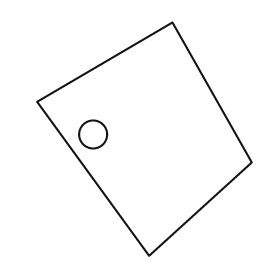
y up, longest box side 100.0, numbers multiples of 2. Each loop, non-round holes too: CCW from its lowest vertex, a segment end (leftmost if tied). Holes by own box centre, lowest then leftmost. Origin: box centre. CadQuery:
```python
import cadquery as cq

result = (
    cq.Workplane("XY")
    .moveTo(2.0, -50.0)
    .lineTo(46.0, -10.0)
    .lineTo(12.0, 50.0)
    .lineTo(-46.0, 16.0)
    .close()
    .moveTo(-22.0, 2.0)
    .circle(6.0)
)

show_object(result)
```